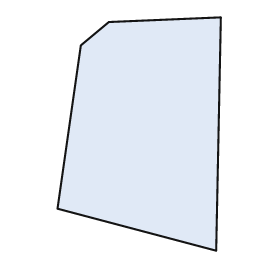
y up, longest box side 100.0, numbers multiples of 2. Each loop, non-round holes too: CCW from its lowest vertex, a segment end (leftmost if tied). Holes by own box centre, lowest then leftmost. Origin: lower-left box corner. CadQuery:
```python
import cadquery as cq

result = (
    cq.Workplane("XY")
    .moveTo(68.0, 0.0)
    .lineTo(70.0, 100.0)
    .lineTo(22.0, 98.0)
    .lineTo(10.0, 88.0)
    .lineTo(0.0, 18.0)
    .close()
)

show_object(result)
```